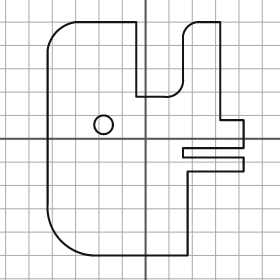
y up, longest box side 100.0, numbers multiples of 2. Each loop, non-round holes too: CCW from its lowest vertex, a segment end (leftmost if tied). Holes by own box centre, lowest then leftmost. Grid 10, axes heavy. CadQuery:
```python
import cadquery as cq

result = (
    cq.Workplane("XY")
    .moveTo(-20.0, -50.0)
    .lineTo(18.0, -50.0)
    .lineTo(18.0, -14.0)
    .lineTo(42.0, -14.0)
    .lineTo(42.0, -8.0)
    .lineTo(16.0, -8.0)
    .lineTo(16.0, -4.0)
    .lineTo(42.0, -4.0)
    .lineTo(42.0, 8.0)
    .lineTo(32.0, 8.0)
    .lineTo(32.0, 50.0)
    .lineTo(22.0, 50.0)
    .threePointArc((18.0, 48.0), (16.0, 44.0))
    .lineTo(16.0, 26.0)
    .threePointArc((14.0, 20.0), (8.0, 18.0))
    .lineTo(-4.0, 18.0)
    .lineTo(-4.0, 50.0)
    .lineTo(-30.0, 50.0)
    .threePointArc((-38.0, 46.0), (-42.0, 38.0))
    .lineTo(-42.0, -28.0)
    .threePointArc((-36.0, -44.0), (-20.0, -50.0))
    .close()
    .moveTo(-18.0, 6.0)
    .circle(4.0)
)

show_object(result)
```